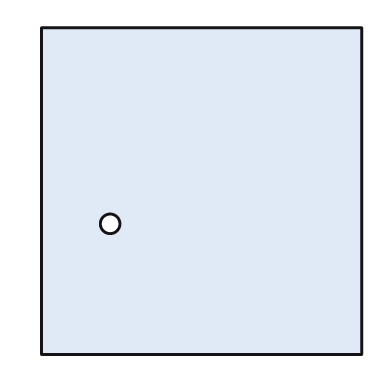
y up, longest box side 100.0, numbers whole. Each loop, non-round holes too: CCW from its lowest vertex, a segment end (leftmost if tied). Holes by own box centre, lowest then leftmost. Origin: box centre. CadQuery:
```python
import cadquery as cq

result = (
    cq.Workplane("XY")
    .moveTo(-49.0, -50.0)
    .lineTo(49.0, -50.0)
    .lineTo(49.0, 50.0)
    .lineTo(-49.0, 50.0)
    .close()
    .moveTo(-28.0, -10.0)
    .circle(3.0)
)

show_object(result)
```